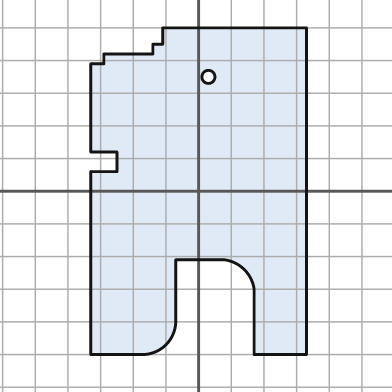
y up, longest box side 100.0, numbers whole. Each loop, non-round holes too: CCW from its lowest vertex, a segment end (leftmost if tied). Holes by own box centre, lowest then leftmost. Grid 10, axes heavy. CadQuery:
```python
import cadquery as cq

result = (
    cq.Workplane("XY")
    .moveTo(-33.0, -50.0)
    .lineTo(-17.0, -50.0)
    .threePointArc((-10.0, -47.0), (-7.0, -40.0))
    .lineTo(-7.0, -21.0)
    .lineTo(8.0, -21.0)
    .threePointArc((14.0, -24.0), (17.0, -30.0))
    .lineTo(17.0, -50.0)
    .lineTo(33.0, -50.0)
    .lineTo(33.0, 50.0)
    .lineTo(-11.0, 50.0)
    .lineTo(-11.0, 45.0)
    .lineTo(-14.0, 45.0)
    .lineTo(-14.0, 42.0)
    .lineTo(-29.0, 42.0)
    .lineTo(-29.0, 39.0)
    .lineTo(-33.0, 39.0)
    .lineTo(-33.0, 12.0)
    .lineTo(-25.0, 12.0)
    .lineTo(-25.0, 6.0)
    .lineTo(-33.0, 6.0)
    .close()
    .moveTo(3.0, 35.0)
    .circle(2.0)
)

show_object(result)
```